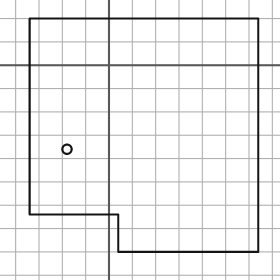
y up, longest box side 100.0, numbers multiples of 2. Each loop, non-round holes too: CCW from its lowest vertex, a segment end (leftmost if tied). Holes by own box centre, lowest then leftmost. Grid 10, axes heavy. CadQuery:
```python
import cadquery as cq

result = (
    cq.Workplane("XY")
    .moveTo(4.0, -80.0)
    .lineTo(64.0, -80.0)
    .lineTo(64.0, 20.0)
    .lineTo(-34.0, 20.0)
    .lineTo(-34.0, -64.0)
    .lineTo(4.0, -64.0)
    .close()
    .moveTo(-18.0, -36.0)
    .circle(2.0)
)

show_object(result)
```